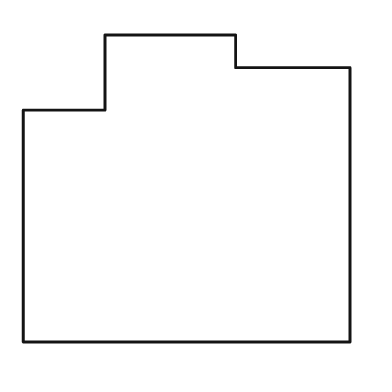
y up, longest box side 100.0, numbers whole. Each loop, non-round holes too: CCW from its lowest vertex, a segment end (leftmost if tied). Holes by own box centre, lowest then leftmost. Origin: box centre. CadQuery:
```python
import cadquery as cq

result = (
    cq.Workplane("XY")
    .moveTo(-50.0, -47.0)
    .lineTo(50.0, -47.0)
    .lineTo(50.0, 37.0)
    .lineTo(15.0, 37.0)
    .lineTo(15.0, 47.0)
    .lineTo(-25.0, 47.0)
    .lineTo(-25.0, 24.0)
    .lineTo(-50.0, 24.0)
    .close()
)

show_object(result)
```